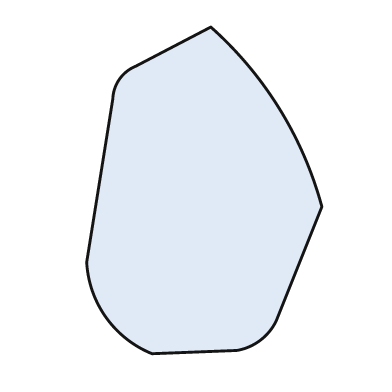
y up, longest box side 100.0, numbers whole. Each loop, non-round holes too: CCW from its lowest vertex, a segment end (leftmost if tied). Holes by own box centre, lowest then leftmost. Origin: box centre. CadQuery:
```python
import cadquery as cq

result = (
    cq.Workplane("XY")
    .moveTo(-16.0, -50.0)
    .lineTo(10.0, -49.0)
    .threePointArc((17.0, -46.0), (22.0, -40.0))
    .lineTo(36.0, -5.0)
    .threePointArc((23.0, 25.0), (2.0, 50.0))
    .lineTo(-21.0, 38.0)
    .threePointArc((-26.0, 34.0), (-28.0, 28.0))
    .lineTo(-36.0, -22.0)
    .threePointArc((-30.0, -39.0), (-16.0, -50.0))
    .close()
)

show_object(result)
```